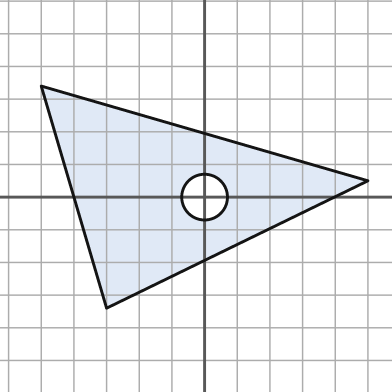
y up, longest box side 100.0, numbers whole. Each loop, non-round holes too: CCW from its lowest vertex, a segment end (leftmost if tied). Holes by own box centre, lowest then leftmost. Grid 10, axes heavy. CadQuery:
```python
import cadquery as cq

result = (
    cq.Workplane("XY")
    .moveTo(-30.0, -34.0)
    .lineTo(50.0, 5.0)
    .lineTo(-50.0, 34.0)
    .close()
    .moveTo(0.0, 0.0)
    .circle(7.0)
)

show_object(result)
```